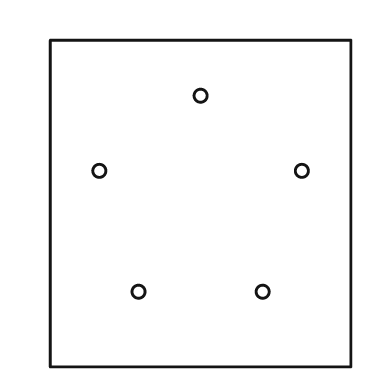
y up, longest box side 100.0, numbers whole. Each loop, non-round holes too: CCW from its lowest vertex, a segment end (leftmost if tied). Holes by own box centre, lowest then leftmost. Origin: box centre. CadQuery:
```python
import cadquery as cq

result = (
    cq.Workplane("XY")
    .moveTo(-46.0, -50.0)
    .lineTo(46.0, -50.0)
    .lineTo(46.0, 50.0)
    .lineTo(-46.0, 50.0)
    .close()
    .moveTo(-19.0, -27.0)
    .circle(2.0)
    .moveTo(19.0, -27.0)
    .circle(2.0)
    .moveTo(-31.0, 10.0)
    .circle(2.0)
    .moveTo(31.0, 10.0)
    .circle(2.0)
    .moveTo(0.0, 33.0)
    .circle(2.0)
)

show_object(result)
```